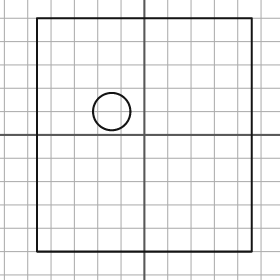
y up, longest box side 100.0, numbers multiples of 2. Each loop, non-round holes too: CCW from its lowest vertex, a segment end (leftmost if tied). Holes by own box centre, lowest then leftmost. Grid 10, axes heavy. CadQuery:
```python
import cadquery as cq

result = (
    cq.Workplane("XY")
    .moveTo(-46.0, -50.0)
    .lineTo(46.0, -50.0)
    .lineTo(46.0, 50.0)
    .lineTo(-46.0, 50.0)
    .close()
    .moveTo(-14.0, 10.0)
    .circle(8.0)
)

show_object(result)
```